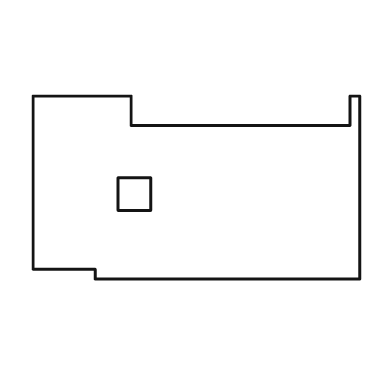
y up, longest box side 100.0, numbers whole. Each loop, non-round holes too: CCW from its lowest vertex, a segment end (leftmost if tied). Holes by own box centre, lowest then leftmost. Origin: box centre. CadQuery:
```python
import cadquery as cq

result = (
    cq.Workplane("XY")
    .moveTo(-31.0, -28.0)
    .lineTo(50.0, -28.0)
    .lineTo(50.0, 28.0)
    .lineTo(47.0, 28.0)
    .lineTo(47.0, 19.0)
    .lineTo(-20.0, 19.0)
    .lineTo(-20.0, 28.0)
    .lineTo(-50.0, 28.0)
    .lineTo(-50.0, -25.0)
    .lineTo(-31.0, -25.0)
    .close()
    .moveTo(-24.0, -7.0)
    .lineTo(-14.0, -7.0)
    .lineTo(-14.0, 3.0)
    .lineTo(-24.0, 3.0)
    .close()
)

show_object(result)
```